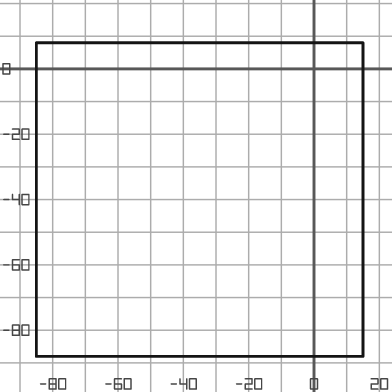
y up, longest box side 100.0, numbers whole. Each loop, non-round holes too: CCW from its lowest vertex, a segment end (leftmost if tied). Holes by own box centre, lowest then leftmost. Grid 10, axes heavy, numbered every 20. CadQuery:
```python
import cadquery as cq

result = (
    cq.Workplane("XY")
    .moveTo(-85.0, -88.0)
    .lineTo(15.0, -88.0)
    .lineTo(15.0, 8.0)
    .lineTo(-85.0, 8.0)
    .close()
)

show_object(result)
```